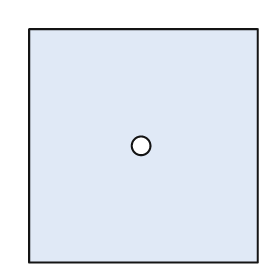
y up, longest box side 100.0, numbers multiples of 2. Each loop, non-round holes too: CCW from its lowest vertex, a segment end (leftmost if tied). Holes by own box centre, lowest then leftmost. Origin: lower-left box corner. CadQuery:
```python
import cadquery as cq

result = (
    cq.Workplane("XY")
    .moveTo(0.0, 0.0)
    .lineTo(98.0, 0.0)
    .lineTo(98.0, 100.0)
    .lineTo(0.0, 100.0)
    .close()
    .moveTo(48.0, 50.0)
    .circle(4.0)
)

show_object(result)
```